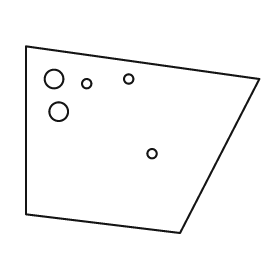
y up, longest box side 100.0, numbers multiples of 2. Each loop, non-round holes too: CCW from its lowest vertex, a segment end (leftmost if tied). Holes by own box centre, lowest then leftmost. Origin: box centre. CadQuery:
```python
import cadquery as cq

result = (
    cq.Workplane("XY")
    .moveTo(16.0, -40.0)
    .lineTo(50.0, 26.0)
    .lineTo(-50.0, 40.0)
    .lineTo(-50.0, -32.0)
    .close()
    .moveTo(4.0, -6.0)
    .circle(2.0)
    .moveTo(-36.0, 12.0)
    .circle(4.0)
    .moveTo(-24.0, 24.0)
    .circle(2.0)
    .moveTo(-38.0, 26.0)
    .circle(4.0)
    .moveTo(-6.0, 26.0)
    .circle(2.0)
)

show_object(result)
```